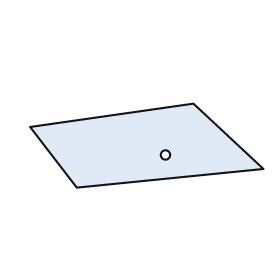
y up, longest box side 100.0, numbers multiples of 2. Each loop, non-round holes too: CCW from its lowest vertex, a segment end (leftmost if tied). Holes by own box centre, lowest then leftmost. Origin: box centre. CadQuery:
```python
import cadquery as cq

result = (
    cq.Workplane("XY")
    .moveTo(-30.0, -18.0)
    .lineTo(50.0, -10.0)
    .lineTo(20.0, 18.0)
    .lineTo(-50.0, 8.0)
    .close()
    .moveTo(8.0, -4.0)
    .circle(2.0)
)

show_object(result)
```